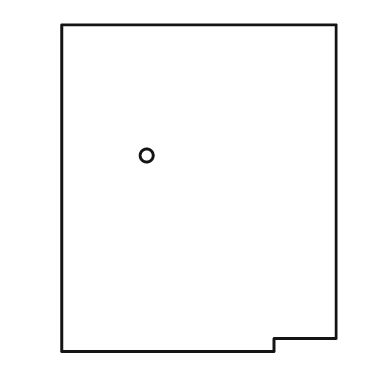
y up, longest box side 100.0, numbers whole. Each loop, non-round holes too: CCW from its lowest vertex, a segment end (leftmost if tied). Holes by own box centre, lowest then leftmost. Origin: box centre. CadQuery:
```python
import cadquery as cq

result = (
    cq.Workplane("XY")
    .moveTo(-42.0, -50.0)
    .lineTo(23.0, -50.0)
    .lineTo(23.0, -46.0)
    .lineTo(42.0, -46.0)
    .lineTo(42.0, 50.0)
    .lineTo(-42.0, 50.0)
    .close()
    .moveTo(-16.0, 10.0)
    .circle(2.0)
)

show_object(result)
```